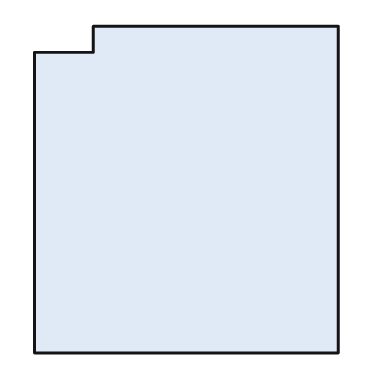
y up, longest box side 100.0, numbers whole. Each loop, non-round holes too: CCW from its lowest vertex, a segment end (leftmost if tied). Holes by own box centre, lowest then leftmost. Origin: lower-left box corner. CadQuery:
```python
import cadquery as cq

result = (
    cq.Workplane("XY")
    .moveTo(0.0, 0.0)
    .lineTo(93.0, 0.0)
    .lineTo(93.0, 100.0)
    .lineTo(18.0, 100.0)
    .lineTo(18.0, 92.0)
    .lineTo(0.0, 92.0)
    .close()
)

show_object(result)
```